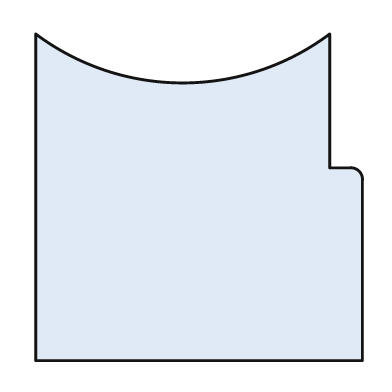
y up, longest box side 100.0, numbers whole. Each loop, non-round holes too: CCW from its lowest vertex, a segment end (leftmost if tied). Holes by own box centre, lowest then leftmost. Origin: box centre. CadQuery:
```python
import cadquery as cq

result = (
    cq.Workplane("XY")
    .moveTo(-50.0, -50.0)
    .lineTo(50.0, -50.0)
    .lineTo(50.0, 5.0)
    .threePointArc((49.0, 8.0), (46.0, 9.0))
    .lineTo(40.0, 9.0)
    .lineTo(40.0, 50.0)
    .threePointArc((-5.0, 35.0), (-50.0, 50.0))
    .close()
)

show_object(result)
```